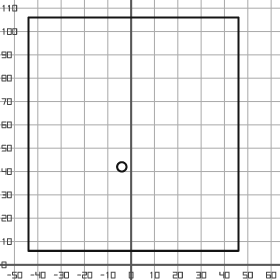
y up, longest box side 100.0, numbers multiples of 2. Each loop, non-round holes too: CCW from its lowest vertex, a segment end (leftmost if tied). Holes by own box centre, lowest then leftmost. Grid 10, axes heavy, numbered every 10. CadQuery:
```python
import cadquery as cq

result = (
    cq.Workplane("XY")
    .moveTo(-44.0, 6.0)
    .lineTo(46.0, 6.0)
    .lineTo(46.0, 106.0)
    .lineTo(-44.0, 106.0)
    .close()
    .moveTo(-4.0, 42.0)
    .circle(2.0)
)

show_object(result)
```